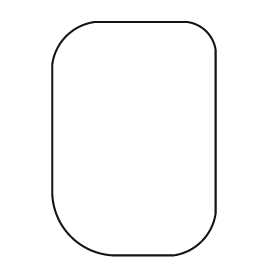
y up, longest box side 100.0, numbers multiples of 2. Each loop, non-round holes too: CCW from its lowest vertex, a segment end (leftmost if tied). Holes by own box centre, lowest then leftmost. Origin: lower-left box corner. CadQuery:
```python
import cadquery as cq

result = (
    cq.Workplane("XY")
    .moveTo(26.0, 0.0)
    .lineTo(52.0, 0.0)
    .threePointArc((64.0, 6.0), (70.0, 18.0))
    .lineTo(70.0, 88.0)
    .threePointArc((66.0, 96.0), (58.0, 100.0))
    .lineTo(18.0, 100.0)
    .threePointArc((6.0, 94.0), (0.0, 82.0))
    .lineTo(0.0, 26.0)
    .threePointArc((8.0, 8.0), (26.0, 0.0))
    .close()
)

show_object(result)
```